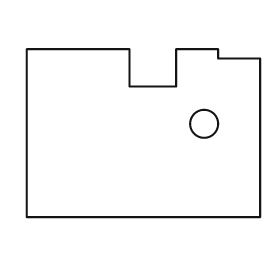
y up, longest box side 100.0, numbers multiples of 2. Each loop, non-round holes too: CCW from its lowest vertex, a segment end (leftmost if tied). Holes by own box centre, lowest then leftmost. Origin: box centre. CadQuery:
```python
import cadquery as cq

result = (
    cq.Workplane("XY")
    .moveTo(-50.0, -36.0)
    .lineTo(50.0, -36.0)
    .lineTo(50.0, 32.0)
    .lineTo(32.0, 32.0)
    .lineTo(32.0, 36.0)
    .lineTo(14.0, 36.0)
    .lineTo(14.0, 20.0)
    .lineTo(-6.0, 20.0)
    .lineTo(-6.0, 36.0)
    .lineTo(-50.0, 36.0)
    .close()
    .moveTo(26.0, 4.0)
    .circle(6.0)
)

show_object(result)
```